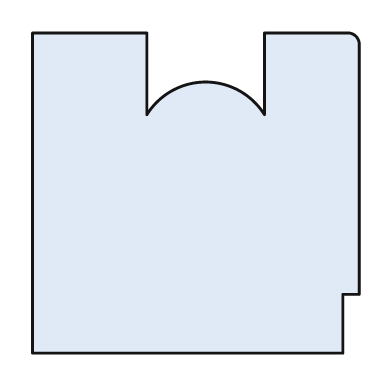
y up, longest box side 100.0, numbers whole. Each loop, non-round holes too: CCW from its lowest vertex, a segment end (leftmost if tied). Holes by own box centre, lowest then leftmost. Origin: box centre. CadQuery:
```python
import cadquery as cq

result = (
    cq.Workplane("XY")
    .moveTo(-50.0, -49.0)
    .lineTo(45.0, -49.0)
    .lineTo(45.0, -31.0)
    .lineTo(50.0, -31.0)
    .lineTo(50.0, 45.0)
    .threePointArc((49.0, 48.0), (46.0, 49.0))
    .lineTo(21.0, 49.0)
    .lineTo(21.0, 24.0)
    .threePointArc((3.0, 34.0), (-15.0, 24.0))
    .lineTo(-15.0, 49.0)
    .lineTo(-50.0, 49.0)
    .close()
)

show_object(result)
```